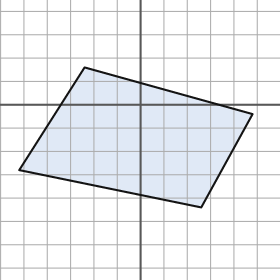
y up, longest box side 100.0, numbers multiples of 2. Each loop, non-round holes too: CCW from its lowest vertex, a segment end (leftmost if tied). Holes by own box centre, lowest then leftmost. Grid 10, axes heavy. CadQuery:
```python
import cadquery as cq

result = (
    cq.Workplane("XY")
    .moveTo(26.0, -44.0)
    .lineTo(48.0, -4.0)
    .lineTo(-24.0, 16.0)
    .lineTo(-52.0, -28.0)
    .close()
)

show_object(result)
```